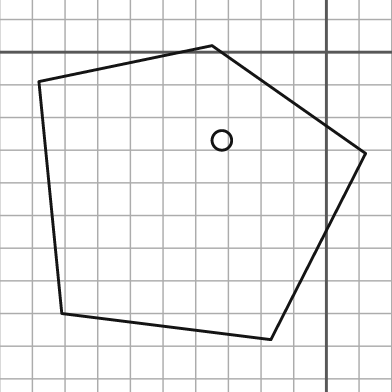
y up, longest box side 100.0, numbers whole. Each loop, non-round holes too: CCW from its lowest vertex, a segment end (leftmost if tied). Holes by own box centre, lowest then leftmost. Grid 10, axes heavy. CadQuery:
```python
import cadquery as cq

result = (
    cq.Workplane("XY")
    .moveTo(-17.0, -88.0)
    .lineTo(12.0, -31.0)
    .lineTo(-35.0, 2.0)
    .lineTo(-88.0, -9.0)
    .lineTo(-81.0, -80.0)
    .close()
    .moveTo(-32.0, -27.0)
    .circle(3.0)
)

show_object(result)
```